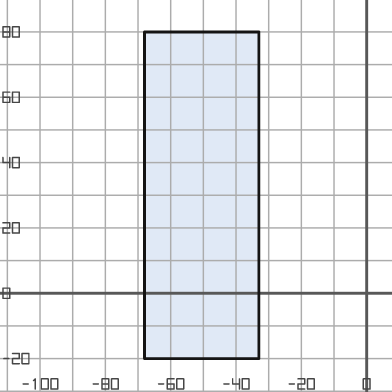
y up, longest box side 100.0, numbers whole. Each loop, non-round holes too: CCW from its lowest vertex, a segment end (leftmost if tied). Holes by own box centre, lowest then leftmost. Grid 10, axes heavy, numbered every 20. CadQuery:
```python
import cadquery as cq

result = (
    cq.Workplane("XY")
    .moveTo(-68.0, -20.0)
    .lineTo(-33.0, -20.0)
    .lineTo(-33.0, 80.0)
    .lineTo(-68.0, 80.0)
    .close()
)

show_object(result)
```